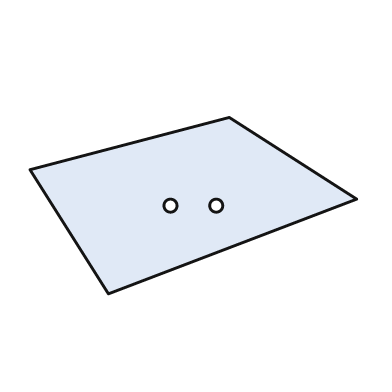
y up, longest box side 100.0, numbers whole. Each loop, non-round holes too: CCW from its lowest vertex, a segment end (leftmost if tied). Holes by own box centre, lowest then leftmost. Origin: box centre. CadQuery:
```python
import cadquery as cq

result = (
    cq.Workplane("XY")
    .moveTo(-26.0, -27.0)
    .lineTo(50.0, 2.0)
    .lineTo(11.0, 27.0)
    .lineTo(-50.0, 11.0)
    .close()
    .moveTo(-7.0, 0.0)
    .circle(2.0)
    .moveTo(7.0, 0.0)
    .circle(2.0)
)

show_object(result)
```